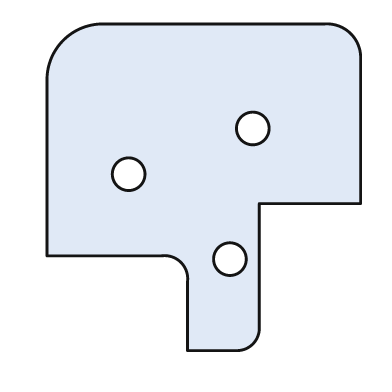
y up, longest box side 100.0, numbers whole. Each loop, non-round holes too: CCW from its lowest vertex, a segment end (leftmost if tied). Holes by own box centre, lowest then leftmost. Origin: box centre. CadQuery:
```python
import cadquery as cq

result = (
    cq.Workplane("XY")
    .moveTo(-5.0, -50.0)
    .lineTo(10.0, -50.0)
    .threePointArc((15.0, -48.0), (17.0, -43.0))
    .lineTo(17.0, -5.0)
    .lineTo(48.0, -5.0)
    .lineTo(48.0, 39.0)
    .threePointArc((45.0, 47.0), (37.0, 50.0))
    .lineTo(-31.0, 50.0)
    .threePointArc((-43.0, 45.0), (-48.0, 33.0))
    .lineTo(-48.0, -21.0)
    .lineTo(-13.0, -21.0)
    .threePointArc((-7.0, -23.0), (-5.0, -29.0))
    .close()
    .moveTo(8.0, -22.0)
    .circle(5.0)
    .moveTo(-23.0, 4.0)
    .circle(5.0)
    .moveTo(15.0, 18.0)
    .circle(5.0)
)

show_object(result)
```